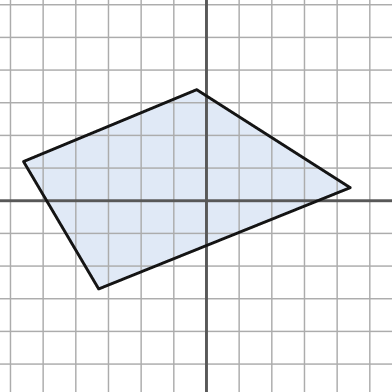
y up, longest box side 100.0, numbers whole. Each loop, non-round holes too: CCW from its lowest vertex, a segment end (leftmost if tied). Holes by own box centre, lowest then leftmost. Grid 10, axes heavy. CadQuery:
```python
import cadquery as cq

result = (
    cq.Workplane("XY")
    .moveTo(-33.0, -27.0)
    .lineTo(44.0, 4.0)
    .lineTo(-3.0, 34.0)
    .lineTo(-56.0, 12.0)
    .close()
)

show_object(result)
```